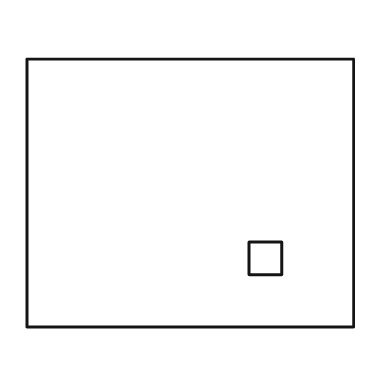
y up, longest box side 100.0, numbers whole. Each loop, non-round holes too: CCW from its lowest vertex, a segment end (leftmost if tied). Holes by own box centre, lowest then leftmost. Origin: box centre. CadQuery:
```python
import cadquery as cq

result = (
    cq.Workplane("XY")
    .moveTo(-50.0, -41.0)
    .lineTo(50.0, -41.0)
    .lineTo(50.0, 41.0)
    .lineTo(-50.0, 41.0)
    .close()
    .moveTo(18.0, -25.0)
    .lineTo(28.0, -25.0)
    .lineTo(28.0, -15.0)
    .lineTo(18.0, -15.0)
    .close()
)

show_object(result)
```